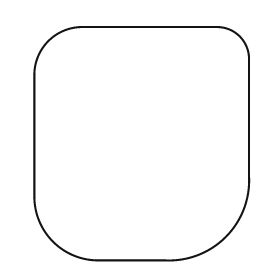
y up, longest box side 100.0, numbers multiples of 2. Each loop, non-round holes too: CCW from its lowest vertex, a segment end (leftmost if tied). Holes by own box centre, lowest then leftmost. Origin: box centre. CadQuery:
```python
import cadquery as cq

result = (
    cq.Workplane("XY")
    .moveTo(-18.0, -50.0)
    .lineTo(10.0, -50.0)
    .threePointArc((36.0, -40.0), (46.0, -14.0))
    .lineTo(46.0, 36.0)
    .threePointArc((42.0, 46.0), (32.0, 50.0))
    .lineTo(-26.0, 50.0)
    .threePointArc((-40.0, 44.0), (-46.0, 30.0))
    .lineTo(-46.0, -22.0)
    .threePointArc((-38.0, -42.0), (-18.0, -50.0))
    .close()
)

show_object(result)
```